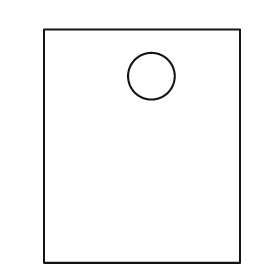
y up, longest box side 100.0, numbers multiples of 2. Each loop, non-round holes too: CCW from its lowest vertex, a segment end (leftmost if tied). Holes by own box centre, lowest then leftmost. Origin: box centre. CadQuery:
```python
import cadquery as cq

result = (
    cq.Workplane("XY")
    .moveTo(-42.0, -50.0)
    .lineTo(42.0, -50.0)
    .lineTo(42.0, 50.0)
    .lineTo(-42.0, 50.0)
    .close()
    .moveTo(4.0, 30.0)
    .circle(10.0)
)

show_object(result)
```